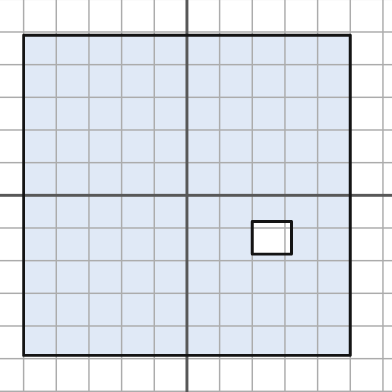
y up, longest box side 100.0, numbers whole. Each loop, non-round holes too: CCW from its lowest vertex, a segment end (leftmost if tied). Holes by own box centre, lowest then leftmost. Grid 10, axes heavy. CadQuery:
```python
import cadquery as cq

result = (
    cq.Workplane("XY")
    .moveTo(-50.0, -49.0)
    .lineTo(50.0, -49.0)
    .lineTo(50.0, 49.0)
    .lineTo(-50.0, 49.0)
    .close()
    .moveTo(20.0, -18.0)
    .lineTo(32.0, -18.0)
    .lineTo(32.0, -8.0)
    .lineTo(20.0, -8.0)
    .close()
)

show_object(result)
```